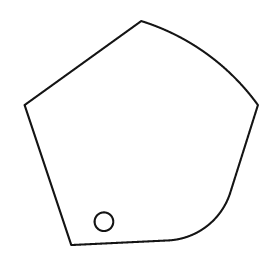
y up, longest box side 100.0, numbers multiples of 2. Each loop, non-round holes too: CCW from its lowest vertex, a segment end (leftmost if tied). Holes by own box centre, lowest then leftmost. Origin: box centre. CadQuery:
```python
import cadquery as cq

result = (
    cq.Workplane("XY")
    .moveTo(-30.0, -48.0)
    .lineTo(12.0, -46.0)
    .threePointArc((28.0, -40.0), (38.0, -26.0))
    .lineTo(50.0, 12.0)
    .threePointArc((28.0, 34.0), (0.0, 48.0))
    .lineTo(-50.0, 12.0)
    .close()
    .moveTo(-16.0, -38.0)
    .circle(4.0)
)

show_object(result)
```